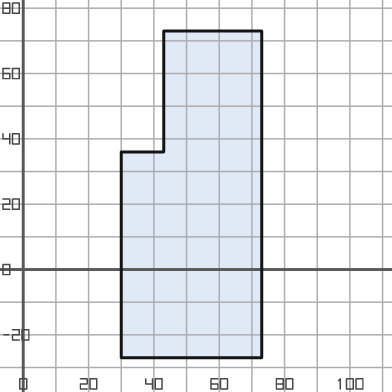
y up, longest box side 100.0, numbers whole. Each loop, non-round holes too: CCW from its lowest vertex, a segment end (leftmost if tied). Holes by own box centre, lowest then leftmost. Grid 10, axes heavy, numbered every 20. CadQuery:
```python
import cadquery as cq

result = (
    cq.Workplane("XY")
    .moveTo(30.0, -27.0)
    .lineTo(73.0, -27.0)
    .lineTo(73.0, 73.0)
    .lineTo(43.0, 73.0)
    .lineTo(43.0, 36.0)
    .lineTo(30.0, 36.0)
    .close()
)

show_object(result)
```